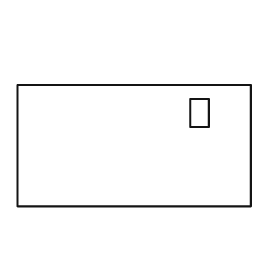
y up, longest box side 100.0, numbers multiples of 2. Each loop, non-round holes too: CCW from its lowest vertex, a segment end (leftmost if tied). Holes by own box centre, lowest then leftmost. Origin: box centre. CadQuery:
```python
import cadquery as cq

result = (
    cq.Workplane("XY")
    .moveTo(-50.0, -26.0)
    .lineTo(50.0, -26.0)
    .lineTo(50.0, 26.0)
    .lineTo(-50.0, 26.0)
    .close()
    .moveTo(24.0, 8.0)
    .lineTo(32.0, 8.0)
    .lineTo(32.0, 20.0)
    .lineTo(24.0, 20.0)
    .close()
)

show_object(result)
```